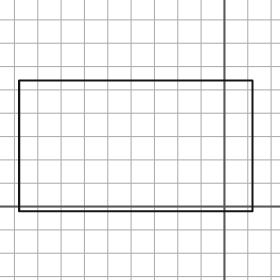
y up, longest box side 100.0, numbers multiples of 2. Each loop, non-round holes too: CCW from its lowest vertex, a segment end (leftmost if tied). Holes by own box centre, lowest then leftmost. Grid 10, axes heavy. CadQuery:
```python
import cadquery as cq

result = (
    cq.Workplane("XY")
    .moveTo(-88.0, -2.0)
    .lineTo(12.0, -2.0)
    .lineTo(12.0, 54.0)
    .lineTo(-88.0, 54.0)
    .close()
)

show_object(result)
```